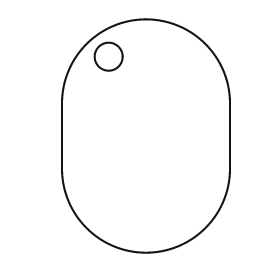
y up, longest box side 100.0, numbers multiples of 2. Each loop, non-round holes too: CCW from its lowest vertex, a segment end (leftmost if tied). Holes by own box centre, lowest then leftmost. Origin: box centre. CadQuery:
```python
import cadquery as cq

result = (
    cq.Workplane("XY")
    .moveTo(-36.0, -14.0)
    .threePointArc((0.0, -50.0), (36.0, -14.0))
    .lineTo(36.0, 14.0)
    .threePointArc((0.0, 50.0), (-36.0, 14.0))
    .close()
    .moveTo(-16.0, 34.0)
    .circle(6.0)
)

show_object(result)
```